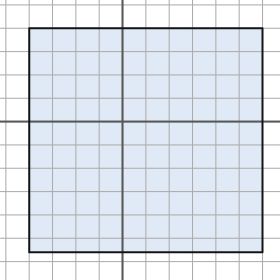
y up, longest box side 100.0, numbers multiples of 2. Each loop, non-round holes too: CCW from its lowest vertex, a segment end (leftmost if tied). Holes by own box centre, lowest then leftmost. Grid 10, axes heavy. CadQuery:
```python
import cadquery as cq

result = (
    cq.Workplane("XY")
    .moveTo(-40.0, -56.0)
    .lineTo(60.0, -56.0)
    .lineTo(60.0, 40.0)
    .lineTo(-40.0, 40.0)
    .close()
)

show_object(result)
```